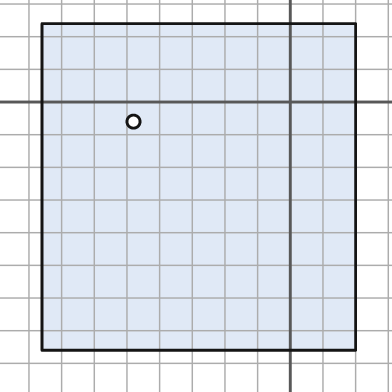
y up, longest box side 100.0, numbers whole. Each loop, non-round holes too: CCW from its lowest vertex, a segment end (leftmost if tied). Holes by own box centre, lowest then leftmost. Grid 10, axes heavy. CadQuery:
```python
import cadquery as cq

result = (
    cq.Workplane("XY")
    .moveTo(-76.0, -76.0)
    .lineTo(20.0, -76.0)
    .lineTo(20.0, 24.0)
    .lineTo(-76.0, 24.0)
    .close()
    .moveTo(-48.0, -6.0)
    .circle(2.0)
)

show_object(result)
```